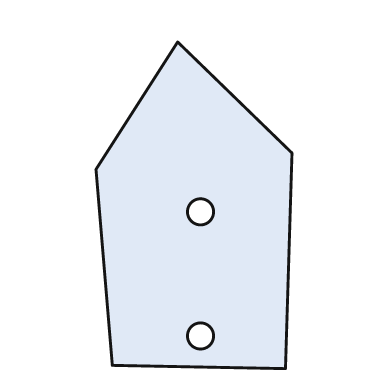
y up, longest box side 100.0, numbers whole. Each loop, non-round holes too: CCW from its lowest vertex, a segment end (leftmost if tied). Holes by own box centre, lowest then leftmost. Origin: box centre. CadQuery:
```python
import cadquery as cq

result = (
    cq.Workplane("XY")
    .moveTo(28.0, -50.0)
    .lineTo(30.0, 16.0)
    .lineTo(-5.0, 50.0)
    .lineTo(-30.0, 11.0)
    .lineTo(-25.0, -49.0)
    .close()
    .moveTo(2.0, -40.0)
    .circle(4.0)
    .moveTo(2.0, -2.0)
    .circle(4.0)
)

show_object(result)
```